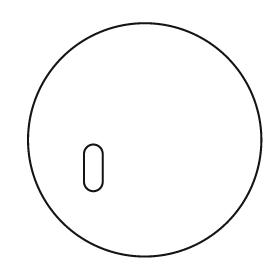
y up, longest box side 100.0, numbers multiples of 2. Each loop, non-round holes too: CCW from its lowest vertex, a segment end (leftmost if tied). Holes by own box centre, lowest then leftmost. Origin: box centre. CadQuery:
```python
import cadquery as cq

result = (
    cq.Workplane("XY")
    .moveTo(0.0, 0.0)
    .circle(50.0)
    .moveTo(-26.0, -18.0)
    .threePointArc((-22.0, -22.0), (-18.0, -18.0))
    .lineTo(-18.0, -6.0)
    .threePointArc((-22.0, -2.0), (-26.0, -6.0))
    .close()
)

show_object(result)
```